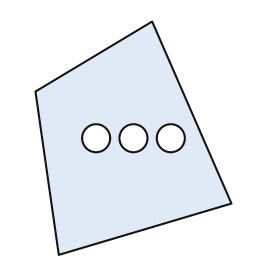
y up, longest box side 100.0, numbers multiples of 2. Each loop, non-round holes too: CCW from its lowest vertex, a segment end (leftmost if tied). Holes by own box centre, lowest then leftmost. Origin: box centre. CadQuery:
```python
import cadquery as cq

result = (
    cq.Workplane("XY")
    .moveTo(-32.0, -50.0)
    .lineTo(42.0, -28.0)
    .lineTo(8.0, 50.0)
    .lineTo(-42.0, 20.0)
    .close()
    .moveTo(-16.0, 0.0)
    .circle(6.0)
    .moveTo(0.0, 0.0)
    .circle(6.0)
    .moveTo(16.0, 0.0)
    .circle(6.0)
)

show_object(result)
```